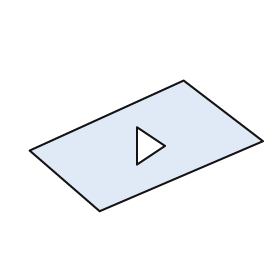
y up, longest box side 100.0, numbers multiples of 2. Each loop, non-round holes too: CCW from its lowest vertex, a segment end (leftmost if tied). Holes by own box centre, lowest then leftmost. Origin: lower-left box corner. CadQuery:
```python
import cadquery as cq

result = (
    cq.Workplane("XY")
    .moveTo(30.0, 0.0)
    .lineTo(100.0, 30.0)
    .lineTo(66.0, 56.0)
    .lineTo(0.0, 26.0)
    .close()
    .moveTo(46.0, 20.0)
    .lineTo(58.0, 28.0)
    .lineTo(46.0, 36.0)
    .close()
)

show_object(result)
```